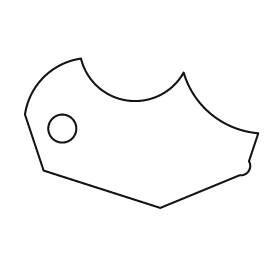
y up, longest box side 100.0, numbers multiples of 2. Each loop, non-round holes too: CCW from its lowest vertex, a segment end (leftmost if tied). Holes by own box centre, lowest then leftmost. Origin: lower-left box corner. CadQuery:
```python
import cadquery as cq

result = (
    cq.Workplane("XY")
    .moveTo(58.0, 0.0)
    .lineTo(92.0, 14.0)
    .threePointArc((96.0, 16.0), (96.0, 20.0))
    .lineTo(100.0, 32.0)
    .threePointArc((80.0, 40.0), (68.0, 58.0))
    .threePointArc((44.0, 46.0), (24.0, 64.0))
    .threePointArc((8.0, 56.0), (0.0, 40.0))
    .lineTo(8.0, 16.0)
    .close()
    .moveTo(16.0, 34.0)
    .circle(6.0)
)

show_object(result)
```